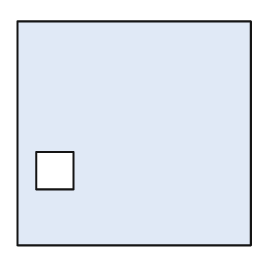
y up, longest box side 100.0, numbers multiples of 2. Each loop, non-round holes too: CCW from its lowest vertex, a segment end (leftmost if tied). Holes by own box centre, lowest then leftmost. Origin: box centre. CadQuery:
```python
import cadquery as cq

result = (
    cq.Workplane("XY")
    .moveTo(-50.0, -48.0)
    .lineTo(50.0, -48.0)
    .lineTo(50.0, 48.0)
    .lineTo(-50.0, 48.0)
    .close()
    .moveTo(-42.0, -24.0)
    .lineTo(-26.0, -24.0)
    .lineTo(-26.0, -8.0)
    .lineTo(-42.0, -8.0)
    .close()
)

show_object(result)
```